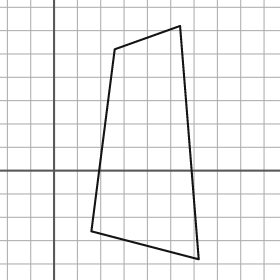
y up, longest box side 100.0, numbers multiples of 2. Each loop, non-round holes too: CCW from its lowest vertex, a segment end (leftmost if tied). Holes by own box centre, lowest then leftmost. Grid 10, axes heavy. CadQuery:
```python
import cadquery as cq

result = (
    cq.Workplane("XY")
    .moveTo(62.0, -38.0)
    .lineTo(54.0, 62.0)
    .lineTo(26.0, 52.0)
    .lineTo(16.0, -26.0)
    .close()
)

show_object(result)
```